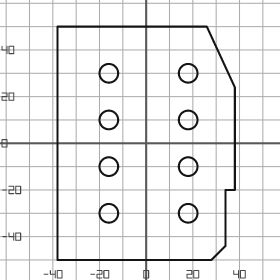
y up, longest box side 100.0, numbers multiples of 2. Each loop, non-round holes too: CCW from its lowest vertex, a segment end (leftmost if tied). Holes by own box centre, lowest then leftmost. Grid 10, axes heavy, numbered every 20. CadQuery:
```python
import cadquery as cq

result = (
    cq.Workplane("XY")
    .moveTo(-38.0, -50.0)
    .lineTo(28.0, -50.0)
    .lineTo(34.0, -44.0)
    .lineTo(34.0, -20.0)
    .lineTo(38.0, -20.0)
    .lineTo(38.0, 24.0)
    .lineTo(26.0, 50.0)
    .lineTo(-38.0, 50.0)
    .close()
    .moveTo(-16.0, -30.0)
    .circle(4.0)
    .moveTo(18.0, -30.0)
    .circle(4.0)
    .moveTo(-16.0, -10.0)
    .circle(4.0)
    .moveTo(18.0, -10.0)
    .circle(4.0)
    .moveTo(-16.0, 10.0)
    .circle(4.0)
    .moveTo(18.0, 10.0)
    .circle(4.0)
    .moveTo(-16.0, 30.0)
    .circle(4.0)
    .moveTo(18.0, 30.0)
    .circle(4.0)
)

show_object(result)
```